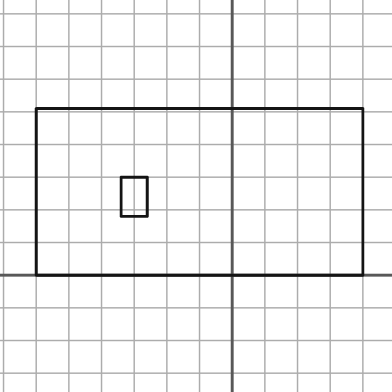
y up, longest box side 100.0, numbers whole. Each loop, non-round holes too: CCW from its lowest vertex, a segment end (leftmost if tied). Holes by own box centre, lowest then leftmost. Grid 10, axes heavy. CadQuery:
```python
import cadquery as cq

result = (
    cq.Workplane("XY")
    .moveTo(-60.0, 0.0)
    .lineTo(40.0, 0.0)
    .lineTo(40.0, 51.0)
    .lineTo(-60.0, 51.0)
    .close()
    .moveTo(-34.0, 18.0)
    .lineTo(-26.0, 18.0)
    .lineTo(-26.0, 30.0)
    .lineTo(-34.0, 30.0)
    .close()
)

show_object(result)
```